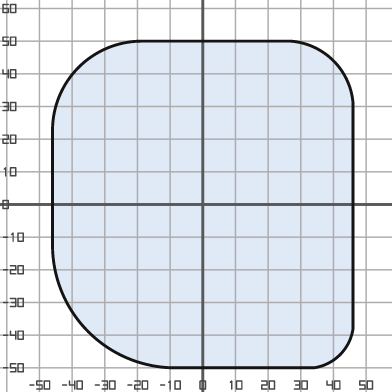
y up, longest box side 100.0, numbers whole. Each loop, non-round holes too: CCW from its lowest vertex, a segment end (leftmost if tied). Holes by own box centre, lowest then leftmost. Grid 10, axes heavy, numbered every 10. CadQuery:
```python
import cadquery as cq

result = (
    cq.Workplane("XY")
    .moveTo(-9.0, -50.0)
    .lineTo(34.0, -50.0)
    .threePointArc((42.0, -46.0), (46.0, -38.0))
    .lineTo(46.0, 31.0)
    .threePointArc((40.0, 44.0), (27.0, 50.0))
    .lineTo(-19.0, 50.0)
    .threePointArc((-38.0, 42.0), (-46.0, 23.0))
    .lineTo(-46.0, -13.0)
    .threePointArc((-35.0, -39.0), (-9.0, -50.0))
    .close()
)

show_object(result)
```